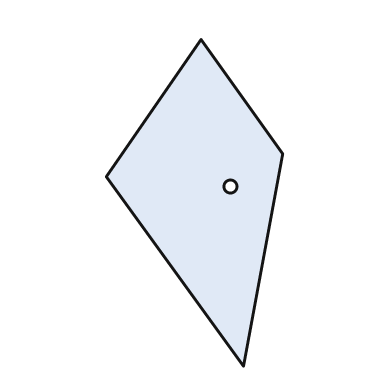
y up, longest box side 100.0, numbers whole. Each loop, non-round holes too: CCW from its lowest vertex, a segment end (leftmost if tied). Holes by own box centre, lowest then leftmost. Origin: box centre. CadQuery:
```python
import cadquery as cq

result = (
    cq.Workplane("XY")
    .moveTo(15.0, -50.0)
    .lineTo(27.0, 15.0)
    .lineTo(2.0, 50.0)
    .lineTo(-27.0, 8.0)
    .close()
    .moveTo(11.0, 5.0)
    .circle(2.0)
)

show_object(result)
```